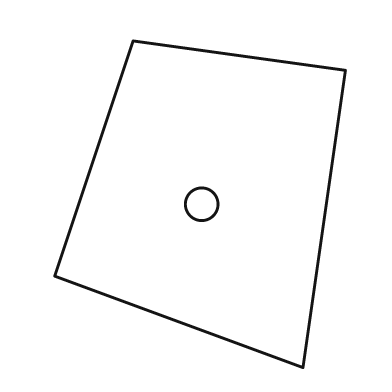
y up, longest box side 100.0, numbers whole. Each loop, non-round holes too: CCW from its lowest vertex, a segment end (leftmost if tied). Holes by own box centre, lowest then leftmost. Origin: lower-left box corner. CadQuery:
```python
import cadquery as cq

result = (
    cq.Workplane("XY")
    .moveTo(76.0, 0.0)
    .lineTo(89.0, 91.0)
    .lineTo(24.0, 100.0)
    .lineTo(0.0, 28.0)
    .close()
    .moveTo(45.0, 50.0)
    .circle(5.0)
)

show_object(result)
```